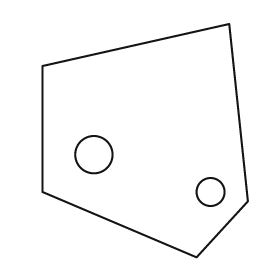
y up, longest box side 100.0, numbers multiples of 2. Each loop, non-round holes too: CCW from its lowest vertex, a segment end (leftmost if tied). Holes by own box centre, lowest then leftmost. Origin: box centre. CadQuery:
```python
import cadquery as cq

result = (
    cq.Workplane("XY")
    .moveTo(22.0, -50.0)
    .lineTo(44.0, -26.0)
    .lineTo(36.0, 50.0)
    .lineTo(-44.0, 32.0)
    .lineTo(-44.0, -22.0)
    .close()
    .moveTo(28.0, -22.0)
    .circle(6.0)
    .moveTo(-22.0, -6.0)
    .circle(8.0)
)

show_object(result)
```